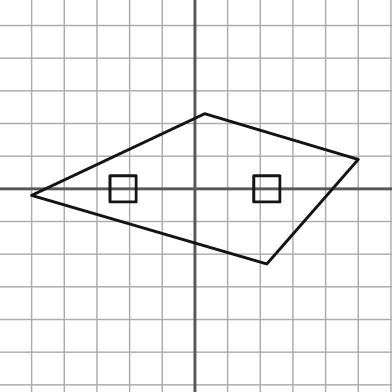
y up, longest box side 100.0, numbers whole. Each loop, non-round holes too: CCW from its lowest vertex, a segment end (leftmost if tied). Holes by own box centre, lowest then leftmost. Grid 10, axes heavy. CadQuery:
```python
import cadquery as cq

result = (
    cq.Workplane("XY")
    .moveTo(22.0, -23.0)
    .lineTo(50.0, 9.0)
    .lineTo(3.0, 23.0)
    .lineTo(-50.0, -2.0)
    .close()
    .moveTo(-26.0, -4.0)
    .lineTo(-18.0, -4.0)
    .lineTo(-18.0, 4.0)
    .lineTo(-26.0, 4.0)
    .close()
    .moveTo(18.0, -4.0)
    .lineTo(26.0, -4.0)
    .lineTo(26.0, 4.0)
    .lineTo(18.0, 4.0)
    .close()
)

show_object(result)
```